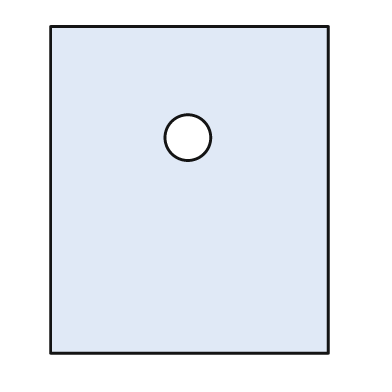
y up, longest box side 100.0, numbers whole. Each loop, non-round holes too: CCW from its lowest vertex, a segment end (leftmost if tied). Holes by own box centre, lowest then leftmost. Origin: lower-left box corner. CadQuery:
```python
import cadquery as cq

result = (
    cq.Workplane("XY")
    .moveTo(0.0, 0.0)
    .lineTo(85.0, 0.0)
    .lineTo(85.0, 100.0)
    .lineTo(0.0, 100.0)
    .close()
    .moveTo(42.0, 66.0)
    .circle(7.0)
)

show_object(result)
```